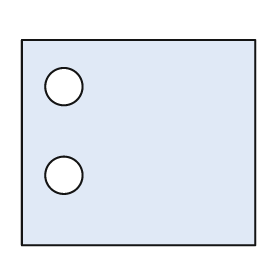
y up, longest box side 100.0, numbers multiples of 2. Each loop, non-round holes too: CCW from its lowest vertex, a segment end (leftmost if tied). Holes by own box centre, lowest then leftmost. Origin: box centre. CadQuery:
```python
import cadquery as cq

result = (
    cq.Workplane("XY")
    .moveTo(-50.0, -44.0)
    .lineTo(50.0, -44.0)
    .lineTo(50.0, 44.0)
    .lineTo(-50.0, 44.0)
    .close()
    .moveTo(-32.0, -14.0)
    .circle(8.0)
    .moveTo(-32.0, 24.0)
    .circle(8.0)
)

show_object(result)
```